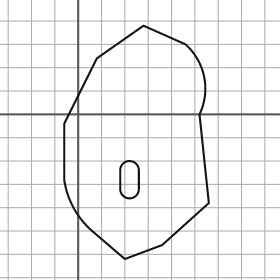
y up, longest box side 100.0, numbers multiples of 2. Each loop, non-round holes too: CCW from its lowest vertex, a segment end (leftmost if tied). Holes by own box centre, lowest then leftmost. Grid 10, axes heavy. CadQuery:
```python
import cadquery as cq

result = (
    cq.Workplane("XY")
    .moveTo(20.0, -62.0)
    .lineTo(36.0, -56.0)
    .lineTo(56.0, -38.0)
    .lineTo(52.0, 0.0)
    .threePointArc((54.0, 16.0), (46.0, 30.0))
    .lineTo(28.0, 38.0)
    .lineTo(8.0, 24.0)
    .lineTo(-6.0, -4.0)
    .lineTo(-6.0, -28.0)
    .threePointArc((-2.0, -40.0), (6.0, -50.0))
    .close()
    .moveTo(18.0, -32.0)
    .threePointArc((22.0, -36.0), (26.0, -32.0))
    .lineTo(26.0, -24.0)
    .threePointArc((22.0, -20.0), (18.0, -24.0))
    .close()
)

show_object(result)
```